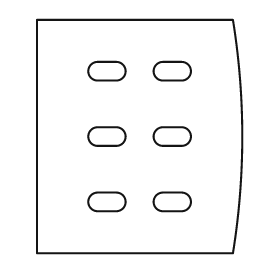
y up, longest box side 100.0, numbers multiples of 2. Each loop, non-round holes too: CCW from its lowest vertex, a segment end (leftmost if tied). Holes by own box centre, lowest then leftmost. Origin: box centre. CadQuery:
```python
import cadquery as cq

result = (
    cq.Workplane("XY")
    .moveTo(-44.0, -50.0)
    .lineTo(40.0, -50.0)
    .threePointArc((44.0, 0.0), (40.0, 50.0))
    .lineTo(-44.0, 50.0)
    .close()
    .moveTo(-18.0, -32.0)
    .lineTo(-10.0, -32.0)
    .threePointArc((-6.0, -28.0), (-10.0, -24.0))
    .lineTo(-18.0, -24.0)
    .threePointArc((-22.0, -28.0), (-18.0, -32.0))
    .close()
    .moveTo(10.0, -32.0)
    .lineTo(18.0, -32.0)
    .threePointArc((22.0, -28.0), (18.0, -24.0))
    .lineTo(10.0, -24.0)
    .threePointArc((6.0, -28.0), (10.0, -32.0))
    .close()
    .moveTo(-18.0, -4.0)
    .lineTo(-10.0, -4.0)
    .threePointArc((-6.0, 0.0), (-10.0, 4.0))
    .lineTo(-18.0, 4.0)
    .threePointArc((-22.0, 0.0), (-18.0, -4.0))
    .close()
    .moveTo(10.0, -4.0)
    .lineTo(18.0, -4.0)
    .threePointArc((22.0, 0.0), (18.0, 4.0))
    .lineTo(10.0, 4.0)
    .threePointArc((6.0, 0.0), (10.0, -4.0))
    .close()
    .moveTo(-18.0, 24.0)
    .lineTo(-10.0, 24.0)
    .threePointArc((-6.0, 28.0), (-10.0, 32.0))
    .lineTo(-18.0, 32.0)
    .threePointArc((-22.0, 28.0), (-18.0, 24.0))
    .close()
    .moveTo(10.0, 24.0)
    .lineTo(18.0, 24.0)
    .threePointArc((22.0, 28.0), (18.0, 32.0))
    .lineTo(10.0, 32.0)
    .threePointArc((6.0, 28.0), (10.0, 24.0))
    .close()
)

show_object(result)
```